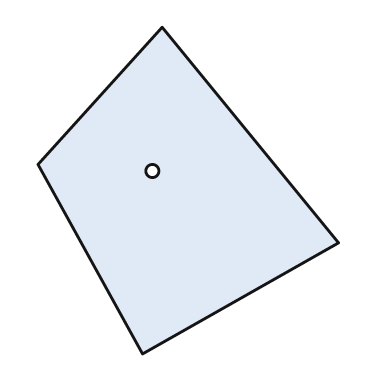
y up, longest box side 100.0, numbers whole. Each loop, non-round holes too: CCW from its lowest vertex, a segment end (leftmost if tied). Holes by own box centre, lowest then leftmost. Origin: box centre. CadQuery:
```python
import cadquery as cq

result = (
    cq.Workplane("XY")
    .moveTo(-14.0, -50.0)
    .lineTo(46.0, -16.0)
    .lineTo(-8.0, 50.0)
    .lineTo(-46.0, 8.0)
    .close()
    .moveTo(-11.0, 6.0)
    .circle(2.0)
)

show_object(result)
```